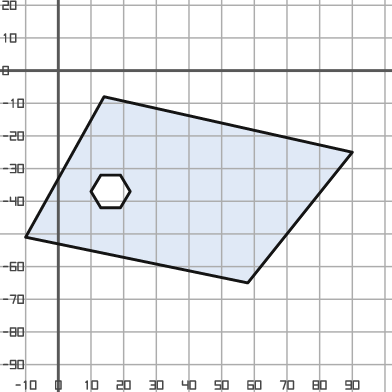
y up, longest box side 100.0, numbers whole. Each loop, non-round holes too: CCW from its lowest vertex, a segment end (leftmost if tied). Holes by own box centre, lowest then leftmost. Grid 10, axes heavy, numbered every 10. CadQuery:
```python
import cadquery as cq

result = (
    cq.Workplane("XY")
    .moveTo(58.0, -65.0)
    .lineTo(90.0, -25.0)
    .lineTo(14.0, -8.0)
    .lineTo(-10.0, -51.0)
    .close()
    .moveTo(13.0, -42.0)
    .lineTo(19.0, -42.0)
    .lineTo(22.0, -37.0)
    .lineTo(19.0, -32.0)
    .lineTo(13.0, -32.0)
    .lineTo(10.0, -37.0)
    .close()
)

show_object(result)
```